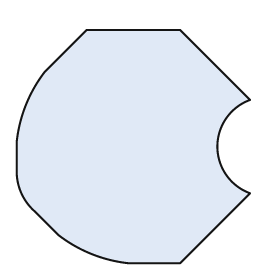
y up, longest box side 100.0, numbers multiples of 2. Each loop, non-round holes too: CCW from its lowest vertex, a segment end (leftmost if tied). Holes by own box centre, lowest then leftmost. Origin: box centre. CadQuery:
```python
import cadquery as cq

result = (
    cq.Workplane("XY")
    .moveTo(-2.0, -50.0)
    .lineTo(20.0, -50.0)
    .lineTo(50.0, -20.0)
    .threePointArc((36.0, 0.0), (50.0, 20.0))
    .lineTo(20.0, 50.0)
    .lineTo(-20.0, 50.0)
    .lineTo(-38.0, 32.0)
    .threePointArc((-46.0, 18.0), (-50.0, 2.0))
    .lineTo(-50.0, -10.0)
    .threePointArc((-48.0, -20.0), (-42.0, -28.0))
    .lineTo(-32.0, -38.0)
    .threePointArc((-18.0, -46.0), (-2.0, -50.0))
    .close()
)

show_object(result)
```